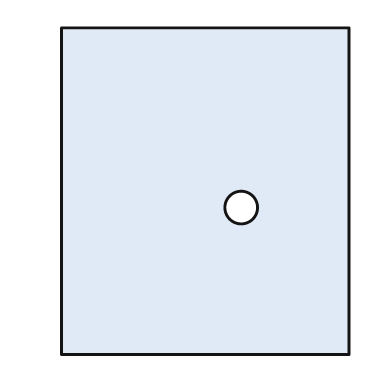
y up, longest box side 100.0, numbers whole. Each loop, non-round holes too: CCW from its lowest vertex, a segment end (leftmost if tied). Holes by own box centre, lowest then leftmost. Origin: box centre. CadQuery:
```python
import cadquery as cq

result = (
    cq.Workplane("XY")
    .moveTo(-44.0, -50.0)
    .lineTo(44.0, -50.0)
    .lineTo(44.0, 50.0)
    .lineTo(-44.0, 50.0)
    .close()
    .moveTo(11.0, -5.0)
    .circle(5.0)
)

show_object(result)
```